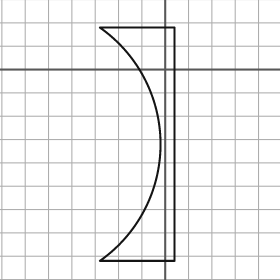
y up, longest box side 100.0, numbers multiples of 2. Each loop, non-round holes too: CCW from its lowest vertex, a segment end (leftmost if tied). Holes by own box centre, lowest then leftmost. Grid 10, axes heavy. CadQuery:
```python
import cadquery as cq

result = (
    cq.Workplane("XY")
    .moveTo(-28.0, -82.0)
    .lineTo(4.0, -82.0)
    .lineTo(4.0, 18.0)
    .lineTo(-28.0, 18.0)
    .threePointArc((-2.0, -32.0), (-28.0, -82.0))
    .close()
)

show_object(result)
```